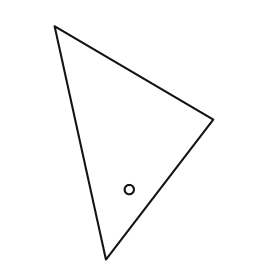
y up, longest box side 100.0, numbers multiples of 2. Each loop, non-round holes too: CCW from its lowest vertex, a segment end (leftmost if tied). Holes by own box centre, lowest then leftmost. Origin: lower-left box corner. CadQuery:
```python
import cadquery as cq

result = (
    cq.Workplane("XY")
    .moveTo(22.0, 0.0)
    .lineTo(68.0, 60.0)
    .lineTo(0.0, 100.0)
    .close()
    .moveTo(32.0, 30.0)
    .circle(2.0)
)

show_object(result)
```